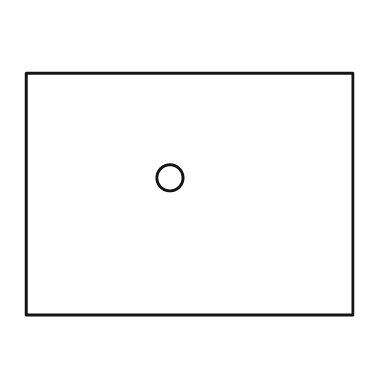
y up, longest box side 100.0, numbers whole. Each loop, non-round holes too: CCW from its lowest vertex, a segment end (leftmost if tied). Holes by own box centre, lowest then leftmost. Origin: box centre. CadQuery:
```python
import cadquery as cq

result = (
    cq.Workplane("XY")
    .moveTo(-50.0, -37.0)
    .lineTo(50.0, -37.0)
    .lineTo(50.0, 37.0)
    .lineTo(-50.0, 37.0)
    .close()
    .moveTo(-6.0, 5.0)
    .circle(4.0)
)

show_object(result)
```